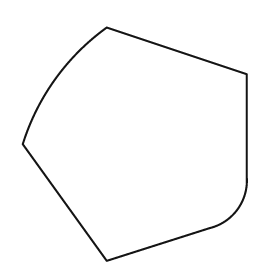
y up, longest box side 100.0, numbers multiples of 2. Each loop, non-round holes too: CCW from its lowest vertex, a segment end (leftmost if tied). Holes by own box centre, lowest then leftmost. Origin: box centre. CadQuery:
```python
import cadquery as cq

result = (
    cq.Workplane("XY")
    .moveTo(-12.0, -50.0)
    .lineTo(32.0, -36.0)
    .threePointArc((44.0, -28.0), (48.0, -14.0))
    .lineTo(48.0, 30.0)
    .lineTo(-12.0, 50.0)
    .threePointArc((-34.0, 28.0), (-48.0, 0.0))
    .close()
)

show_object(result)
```